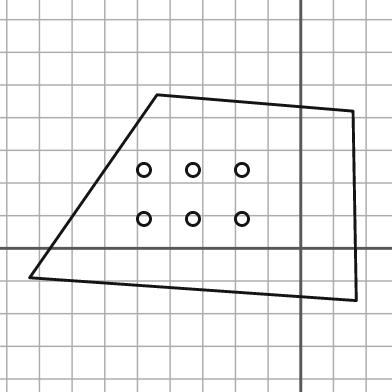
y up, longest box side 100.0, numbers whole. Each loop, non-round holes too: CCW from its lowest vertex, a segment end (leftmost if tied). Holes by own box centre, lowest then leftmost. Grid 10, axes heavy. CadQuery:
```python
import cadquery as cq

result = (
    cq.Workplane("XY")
    .moveTo(17.0, -16.0)
    .lineTo(16.0, 42.0)
    .lineTo(-44.0, 47.0)
    .lineTo(-83.0, -9.0)
    .close()
    .moveTo(-48.0, 9.0)
    .circle(2.0)
    .moveTo(-33.0, 9.0)
    .circle(2.0)
    .moveTo(-18.0, 9.0)
    .circle(2.0)
    .moveTo(-48.0, 24.0)
    .circle(2.0)
    .moveTo(-33.0, 24.0)
    .circle(2.0)
    .moveTo(-18.0, 24.0)
    .circle(2.0)
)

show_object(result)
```